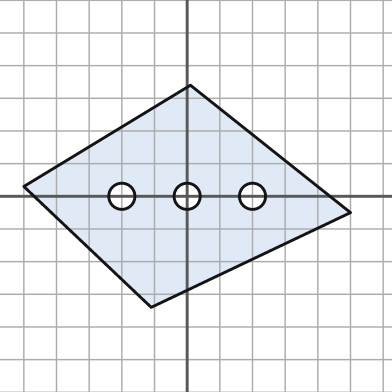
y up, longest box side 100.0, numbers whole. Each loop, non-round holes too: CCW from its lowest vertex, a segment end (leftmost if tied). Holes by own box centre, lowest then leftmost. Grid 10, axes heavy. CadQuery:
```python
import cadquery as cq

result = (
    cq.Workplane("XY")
    .moveTo(-11.0, -34.0)
    .lineTo(50.0, -5.0)
    .lineTo(1.0, 34.0)
    .lineTo(-50.0, 3.0)
    .close()
    .moveTo(-20.0, 0.0)
    .circle(4.0)
    .moveTo(0.0, 0.0)
    .circle(4.0)
    .moveTo(20.0, 0.0)
    .circle(4.0)
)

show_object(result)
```